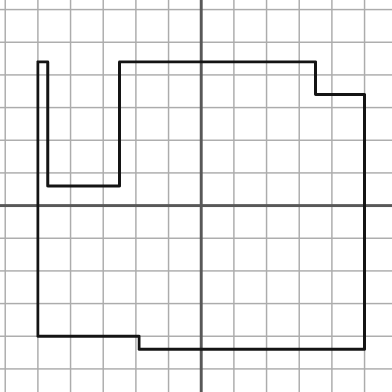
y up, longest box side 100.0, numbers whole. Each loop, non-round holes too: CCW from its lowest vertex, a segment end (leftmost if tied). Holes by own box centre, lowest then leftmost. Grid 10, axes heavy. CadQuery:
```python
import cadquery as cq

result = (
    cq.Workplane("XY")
    .moveTo(-19.0, -44.0)
    .lineTo(50.0, -44.0)
    .lineTo(50.0, 34.0)
    .lineTo(35.0, 34.0)
    .lineTo(35.0, 44.0)
    .lineTo(-25.0, 44.0)
    .lineTo(-25.0, 6.0)
    .lineTo(-47.0, 6.0)
    .lineTo(-47.0, 44.0)
    .lineTo(-50.0, 44.0)
    .lineTo(-50.0, -40.0)
    .lineTo(-19.0, -40.0)
    .close()
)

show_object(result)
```